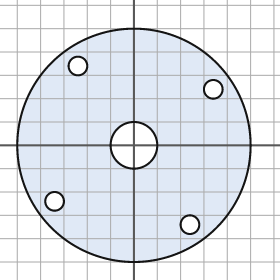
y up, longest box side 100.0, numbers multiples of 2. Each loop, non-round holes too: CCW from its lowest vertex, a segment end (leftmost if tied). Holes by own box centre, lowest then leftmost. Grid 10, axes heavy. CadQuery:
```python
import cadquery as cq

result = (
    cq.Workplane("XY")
    .moveTo(0.0, 0.0)
    .circle(50.0)
    .moveTo(24.0, -34.0)
    .circle(4.0)
    .moveTo(-34.0, -24.0)
    .circle(4.0)
    .moveTo(0.0, 0.0)
    .circle(10.0)
    .moveTo(34.0, 24.0)
    .circle(4.0)
    .moveTo(-24.0, 34.0)
    .circle(4.0)
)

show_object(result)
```